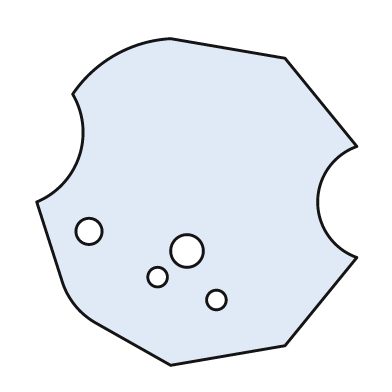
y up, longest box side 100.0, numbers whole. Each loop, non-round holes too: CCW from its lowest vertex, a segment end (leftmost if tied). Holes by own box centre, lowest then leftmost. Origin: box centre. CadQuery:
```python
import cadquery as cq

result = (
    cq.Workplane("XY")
    .moveTo(-8.0, -50.0)
    .lineTo(27.0, -44.0)
    .lineTo(49.0, -17.0)
    .threePointArc((37.0, 0.0), (49.0, 17.0))
    .lineTo(27.0, 44.0)
    .lineTo(-8.0, 50.0)
    .threePointArc((-25.0, 45.0), (-38.0, 33.0))
    .threePointArc((-36.0, 14.0), (-49.0, 0.0))
    .lineTo(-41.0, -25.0)
    .threePointArc((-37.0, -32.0), (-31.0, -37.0))
    .close()
    .moveTo(6.0, -30.0)
    .circle(3.0)
    .moveTo(-12.0, -23.0)
    .circle(3.0)
    .moveTo(-3.0, -15.0)
    .circle(5.0)
    .moveTo(-33.0, -9.0)
    .circle(4.0)
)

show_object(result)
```